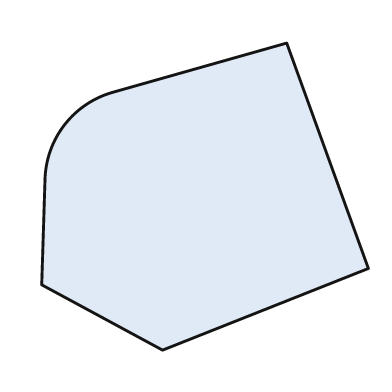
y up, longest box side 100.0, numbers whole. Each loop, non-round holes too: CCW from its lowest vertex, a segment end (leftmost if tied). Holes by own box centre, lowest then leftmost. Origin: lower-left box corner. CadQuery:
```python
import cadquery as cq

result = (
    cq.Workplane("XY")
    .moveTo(37.0, 0.0)
    .lineTo(100.0, 25.0)
    .lineTo(75.0, 94.0)
    .lineTo(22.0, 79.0)
    .threePointArc((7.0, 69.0), (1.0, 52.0))
    .lineTo(0.0, 20.0)
    .close()
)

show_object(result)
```